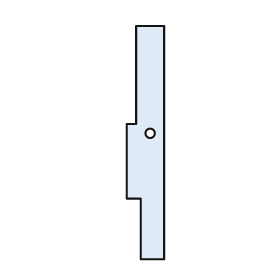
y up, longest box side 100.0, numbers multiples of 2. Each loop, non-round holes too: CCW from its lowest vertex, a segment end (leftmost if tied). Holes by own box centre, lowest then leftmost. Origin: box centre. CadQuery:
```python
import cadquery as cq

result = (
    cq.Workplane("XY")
    .moveTo(-2.0, -50.0)
    .lineTo(8.0, -50.0)
    .lineTo(8.0, 50.0)
    .lineTo(-4.0, 50.0)
    .lineTo(-4.0, 8.0)
    .lineTo(-8.0, 8.0)
    .lineTo(-8.0, -24.0)
    .lineTo(-2.0, -24.0)
    .close()
    .moveTo(2.0, 4.0)
    .circle(2.0)
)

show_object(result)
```